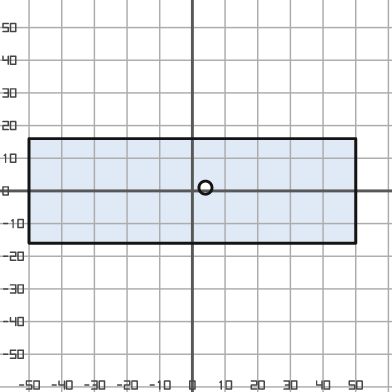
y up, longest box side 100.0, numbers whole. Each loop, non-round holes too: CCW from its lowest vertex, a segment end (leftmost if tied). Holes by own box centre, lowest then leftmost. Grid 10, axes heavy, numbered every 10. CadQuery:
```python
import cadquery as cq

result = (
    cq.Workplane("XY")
    .moveTo(-50.0, -16.0)
    .lineTo(50.0, -16.0)
    .lineTo(50.0, 16.0)
    .lineTo(-50.0, 16.0)
    .close()
    .moveTo(4.0, 1.0)
    .circle(2.0)
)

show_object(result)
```